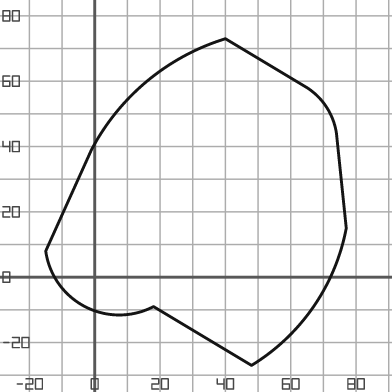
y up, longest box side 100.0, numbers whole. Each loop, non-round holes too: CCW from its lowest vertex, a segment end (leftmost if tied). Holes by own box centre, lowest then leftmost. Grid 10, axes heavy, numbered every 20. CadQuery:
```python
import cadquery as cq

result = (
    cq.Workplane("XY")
    .moveTo(48.0, -27.0)
    .threePointArc((67.0, -9.0), (77.0, 15.0))
    .lineTo(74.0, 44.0)
    .threePointArc((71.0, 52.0), (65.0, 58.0))
    .lineTo(40.0, 73.0)
    .threePointArc((16.0, 60.0), (-1.0, 39.0))
    .lineTo(-15.0, 8.0)
    .threePointArc((-3.0, -9.0), (18.0, -9.0))
    .close()
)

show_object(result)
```